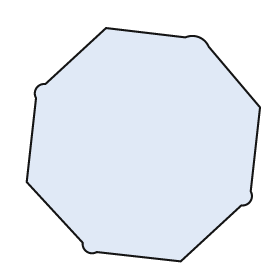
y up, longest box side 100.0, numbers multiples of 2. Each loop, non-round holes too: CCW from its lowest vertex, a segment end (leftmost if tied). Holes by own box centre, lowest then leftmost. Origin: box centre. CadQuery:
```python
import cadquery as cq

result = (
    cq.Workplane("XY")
    .moveTo(16.0, -50.0)
    .lineTo(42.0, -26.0)
    .threePointArc((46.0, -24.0), (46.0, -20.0))
    .lineTo(50.0, 16.0)
    .lineTo(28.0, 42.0)
    .threePointArc((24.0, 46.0), (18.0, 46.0))
    .lineTo(-16.0, 50.0)
    .lineTo(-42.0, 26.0)
    .threePointArc((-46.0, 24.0), (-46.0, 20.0))
    .lineTo(-50.0, -16.0)
    .lineTo(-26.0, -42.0)
    .threePointArc((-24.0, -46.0), (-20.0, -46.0))
    .close()
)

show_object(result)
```